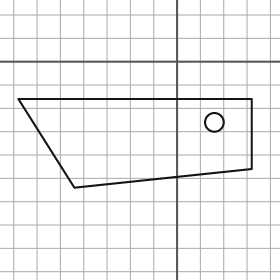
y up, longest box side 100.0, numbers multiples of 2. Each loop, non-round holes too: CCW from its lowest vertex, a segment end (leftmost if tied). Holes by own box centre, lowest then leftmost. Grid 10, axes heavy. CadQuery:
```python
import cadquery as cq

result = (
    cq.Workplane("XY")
    .moveTo(-44.0, -54.0)
    .lineTo(32.0, -46.0)
    .lineTo(32.0, -16.0)
    .lineTo(-68.0, -16.0)
    .close()
    .moveTo(16.0, -26.0)
    .circle(4.0)
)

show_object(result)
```